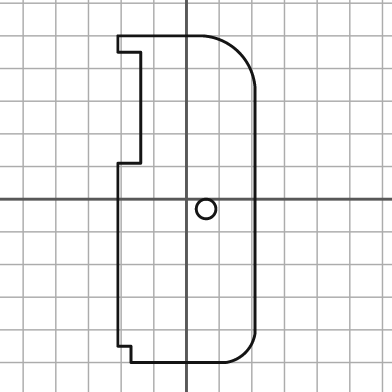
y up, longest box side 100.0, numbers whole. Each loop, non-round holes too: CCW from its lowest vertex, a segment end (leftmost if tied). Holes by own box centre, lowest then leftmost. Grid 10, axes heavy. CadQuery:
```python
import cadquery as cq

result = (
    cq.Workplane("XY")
    .moveTo(-17.0, -50.0)
    .lineTo(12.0, -50.0)
    .threePointArc((18.0, -47.0), (21.0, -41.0))
    .lineTo(21.0, 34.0)
    .threePointArc((16.0, 45.0), (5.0, 50.0))
    .lineTo(-21.0, 50.0)
    .lineTo(-21.0, 45.0)
    .lineTo(-14.0, 45.0)
    .lineTo(-14.0, 11.0)
    .lineTo(-21.0, 11.0)
    .lineTo(-21.0, -45.0)
    .lineTo(-17.0, -45.0)
    .close()
    .moveTo(6.0, -3.0)
    .circle(3.0)
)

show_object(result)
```